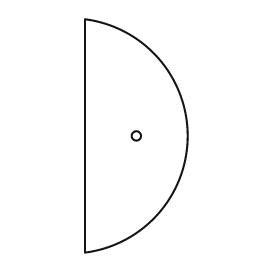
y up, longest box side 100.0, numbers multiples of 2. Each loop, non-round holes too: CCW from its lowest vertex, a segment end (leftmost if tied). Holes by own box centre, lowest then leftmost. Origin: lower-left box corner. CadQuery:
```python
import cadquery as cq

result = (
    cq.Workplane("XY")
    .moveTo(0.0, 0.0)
    .threePointArc((44.0, 50.0), (0.0, 100.0))
    .close()
    .moveTo(22.0, 50.0)
    .circle(2.0)
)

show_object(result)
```